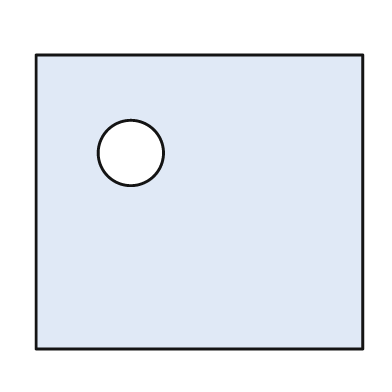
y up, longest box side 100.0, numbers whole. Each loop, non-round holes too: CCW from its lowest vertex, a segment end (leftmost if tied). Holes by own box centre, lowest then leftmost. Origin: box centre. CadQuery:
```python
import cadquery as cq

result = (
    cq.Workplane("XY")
    .moveTo(-50.0, -45.0)
    .lineTo(50.0, -45.0)
    .lineTo(50.0, 45.0)
    .lineTo(-50.0, 45.0)
    .close()
    .moveTo(-21.0, 15.0)
    .circle(10.0)
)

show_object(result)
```